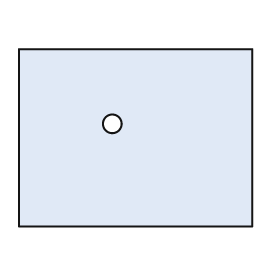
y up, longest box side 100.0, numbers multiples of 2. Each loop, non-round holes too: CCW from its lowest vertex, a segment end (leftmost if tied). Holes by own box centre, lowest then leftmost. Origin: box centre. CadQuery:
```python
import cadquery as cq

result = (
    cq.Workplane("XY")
    .moveTo(-50.0, -38.0)
    .lineTo(50.0, -38.0)
    .lineTo(50.0, 38.0)
    .lineTo(-50.0, 38.0)
    .close()
    .moveTo(-10.0, 6.0)
    .circle(4.0)
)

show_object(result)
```